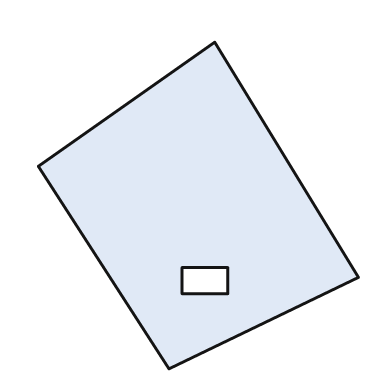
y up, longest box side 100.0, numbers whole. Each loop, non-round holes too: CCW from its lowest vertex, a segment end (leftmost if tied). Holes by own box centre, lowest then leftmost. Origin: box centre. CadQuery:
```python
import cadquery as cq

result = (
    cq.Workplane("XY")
    .moveTo(-9.0, -50.0)
    .lineTo(49.0, -22.0)
    .lineTo(5.0, 50.0)
    .lineTo(-49.0, 12.0)
    .close()
    .moveTo(-5.0, -27.0)
    .lineTo(9.0, -27.0)
    .lineTo(9.0, -19.0)
    .lineTo(-5.0, -19.0)
    .close()
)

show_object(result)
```